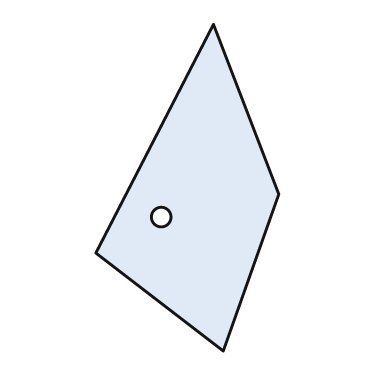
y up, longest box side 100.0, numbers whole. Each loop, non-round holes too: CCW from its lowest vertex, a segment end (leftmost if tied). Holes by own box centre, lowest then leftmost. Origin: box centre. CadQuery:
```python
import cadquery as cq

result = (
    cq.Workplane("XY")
    .moveTo(11.0, -50.0)
    .lineTo(28.0, -2.0)
    .lineTo(8.0, 50.0)
    .lineTo(-28.0, -20.0)
    .close()
    .moveTo(-8.0, -9.0)
    .circle(3.0)
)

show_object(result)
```